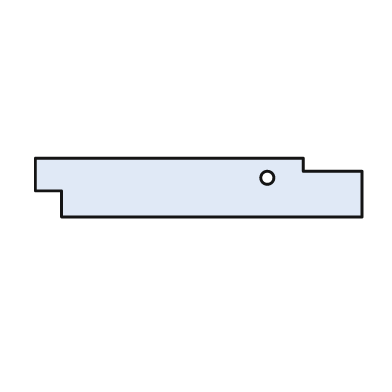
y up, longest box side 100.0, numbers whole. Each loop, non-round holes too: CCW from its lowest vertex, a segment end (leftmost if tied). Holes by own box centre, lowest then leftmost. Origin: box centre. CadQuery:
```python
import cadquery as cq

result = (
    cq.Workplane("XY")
    .moveTo(-42.0, -9.0)
    .lineTo(50.0, -9.0)
    .lineTo(50.0, 5.0)
    .lineTo(32.0, 5.0)
    .lineTo(32.0, 9.0)
    .lineTo(-50.0, 9.0)
    .lineTo(-50.0, -1.0)
    .lineTo(-42.0, -1.0)
    .close()
    .moveTo(21.0, 3.0)
    .circle(2.0)
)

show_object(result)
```